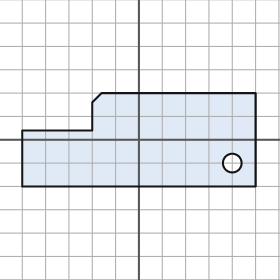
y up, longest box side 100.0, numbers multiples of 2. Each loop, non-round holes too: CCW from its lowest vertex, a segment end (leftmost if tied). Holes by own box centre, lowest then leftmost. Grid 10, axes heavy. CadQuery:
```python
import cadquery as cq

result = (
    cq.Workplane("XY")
    .moveTo(-50.0, -20.0)
    .lineTo(50.0, -20.0)
    .lineTo(50.0, 20.0)
    .lineTo(-16.0, 20.0)
    .lineTo(-20.0, 16.0)
    .lineTo(-20.0, 4.0)
    .lineTo(-50.0, 4.0)
    .close()
    .moveTo(40.0, -10.0)
    .circle(4.0)
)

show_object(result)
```